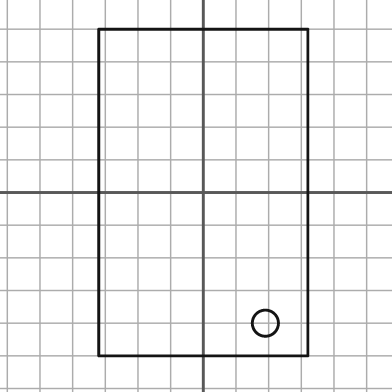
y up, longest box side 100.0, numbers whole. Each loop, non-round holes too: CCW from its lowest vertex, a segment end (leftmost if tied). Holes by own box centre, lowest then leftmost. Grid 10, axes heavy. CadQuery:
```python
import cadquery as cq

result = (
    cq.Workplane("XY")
    .moveTo(-32.0, -50.0)
    .lineTo(32.0, -50.0)
    .lineTo(32.0, 50.0)
    .lineTo(-32.0, 50.0)
    .close()
    .moveTo(19.0, -40.0)
    .circle(4.0)
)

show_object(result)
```